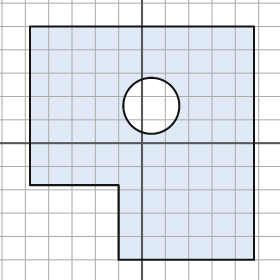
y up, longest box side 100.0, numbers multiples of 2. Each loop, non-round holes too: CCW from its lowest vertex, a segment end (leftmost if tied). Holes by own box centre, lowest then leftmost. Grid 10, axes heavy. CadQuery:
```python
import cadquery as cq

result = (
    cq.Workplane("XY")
    .moveTo(-10.0, -50.0)
    .lineTo(48.0, -50.0)
    .lineTo(48.0, 50.0)
    .lineTo(-48.0, 50.0)
    .lineTo(-48.0, -18.0)
    .lineTo(-10.0, -18.0)
    .close()
    .moveTo(4.0, 16.0)
    .circle(12.0)
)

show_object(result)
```